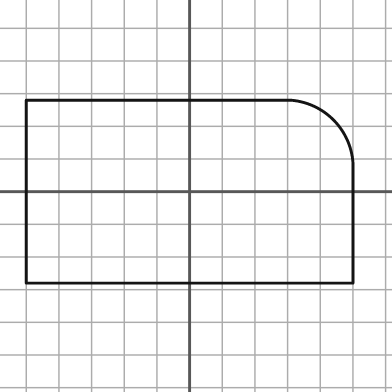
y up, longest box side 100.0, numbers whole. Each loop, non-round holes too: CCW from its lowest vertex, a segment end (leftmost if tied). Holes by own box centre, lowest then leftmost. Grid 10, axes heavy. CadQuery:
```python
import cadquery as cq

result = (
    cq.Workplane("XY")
    .moveTo(-50.0, -28.0)
    .lineTo(50.0, -28.0)
    .lineTo(50.0, 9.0)
    .threePointArc((44.0, 22.0), (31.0, 28.0))
    .lineTo(-50.0, 28.0)
    .close()
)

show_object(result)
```